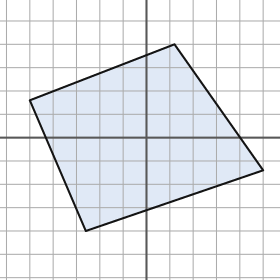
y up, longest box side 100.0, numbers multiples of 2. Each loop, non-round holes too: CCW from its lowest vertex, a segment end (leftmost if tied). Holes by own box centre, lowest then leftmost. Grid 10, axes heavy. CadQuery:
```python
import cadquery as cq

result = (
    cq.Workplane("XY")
    .moveTo(-26.0, -40.0)
    .lineTo(50.0, -14.0)
    .lineTo(12.0, 40.0)
    .lineTo(-50.0, 16.0)
    .close()
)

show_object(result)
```